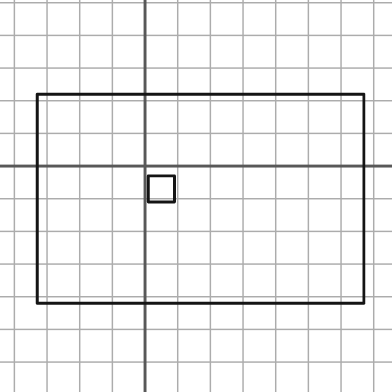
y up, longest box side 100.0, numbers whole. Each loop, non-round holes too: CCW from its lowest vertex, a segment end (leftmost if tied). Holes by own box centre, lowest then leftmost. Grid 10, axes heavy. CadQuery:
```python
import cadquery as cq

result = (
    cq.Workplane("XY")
    .moveTo(-33.0, -42.0)
    .lineTo(67.0, -42.0)
    .lineTo(67.0, 22.0)
    .lineTo(-33.0, 22.0)
    .close()
    .moveTo(1.0, -11.0)
    .lineTo(9.0, -11.0)
    .lineTo(9.0, -3.0)
    .lineTo(1.0, -3.0)
    .close()
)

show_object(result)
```